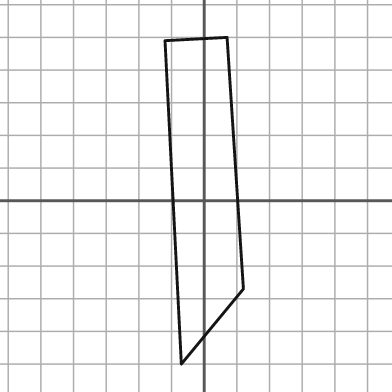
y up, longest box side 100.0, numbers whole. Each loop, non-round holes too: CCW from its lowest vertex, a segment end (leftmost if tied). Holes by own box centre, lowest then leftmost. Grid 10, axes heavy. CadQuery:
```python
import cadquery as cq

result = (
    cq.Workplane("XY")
    .moveTo(-7.0, -50.0)
    .lineTo(12.0, -27.0)
    .lineTo(7.0, 50.0)
    .lineTo(-12.0, 49.0)
    .close()
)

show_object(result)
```